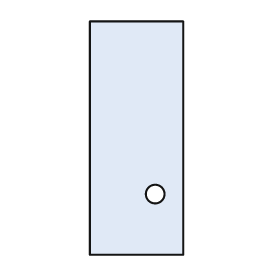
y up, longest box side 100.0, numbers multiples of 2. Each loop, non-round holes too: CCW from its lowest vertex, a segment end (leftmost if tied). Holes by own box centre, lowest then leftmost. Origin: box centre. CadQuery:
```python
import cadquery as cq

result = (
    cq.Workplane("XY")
    .moveTo(-20.0, -50.0)
    .lineTo(20.0, -50.0)
    .lineTo(20.0, 50.0)
    .lineTo(-20.0, 50.0)
    .close()
    .moveTo(8.0, -24.0)
    .circle(4.0)
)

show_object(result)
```